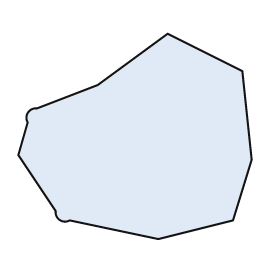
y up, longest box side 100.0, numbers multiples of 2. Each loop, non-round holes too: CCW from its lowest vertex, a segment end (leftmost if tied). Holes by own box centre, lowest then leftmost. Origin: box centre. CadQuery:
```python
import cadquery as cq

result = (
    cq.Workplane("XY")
    .moveTo(10.0, -44.0)
    .lineTo(42.0, -36.0)
    .lineTo(50.0, -10.0)
    .lineTo(46.0, 28.0)
    .lineTo(14.0, 44.0)
    .lineTo(-16.0, 22.0)
    .lineTo(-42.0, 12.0)
    .threePointArc((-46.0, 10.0), (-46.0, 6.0))
    .lineTo(-50.0, -8.0)
    .lineTo(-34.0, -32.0)
    .threePointArc((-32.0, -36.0), (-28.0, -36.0))
    .close()
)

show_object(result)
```